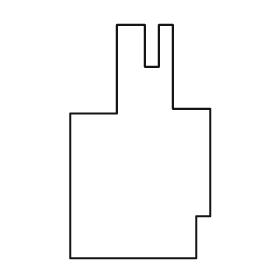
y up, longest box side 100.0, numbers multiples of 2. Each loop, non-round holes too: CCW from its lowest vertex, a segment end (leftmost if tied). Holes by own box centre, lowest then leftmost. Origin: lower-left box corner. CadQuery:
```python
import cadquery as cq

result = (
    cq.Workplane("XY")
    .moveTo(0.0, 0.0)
    .lineTo(54.0, 0.0)
    .lineTo(54.0, 18.0)
    .lineTo(60.0, 18.0)
    .lineTo(60.0, 64.0)
    .lineTo(44.0, 64.0)
    .lineTo(44.0, 100.0)
    .lineTo(38.0, 100.0)
    .lineTo(38.0, 82.0)
    .lineTo(32.0, 82.0)
    .lineTo(32.0, 100.0)
    .lineTo(20.0, 100.0)
    .lineTo(20.0, 62.0)
    .lineTo(0.0, 62.0)
    .close()
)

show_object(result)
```